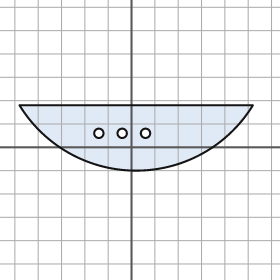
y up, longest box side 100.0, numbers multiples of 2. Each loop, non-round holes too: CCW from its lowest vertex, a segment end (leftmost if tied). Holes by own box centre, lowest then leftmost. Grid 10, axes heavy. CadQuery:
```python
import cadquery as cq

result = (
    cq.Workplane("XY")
    .moveTo(-48.0, 18.0)
    .threePointArc((2.0, -10.0), (52.0, 18.0))
    .close()
    .moveTo(-14.0, 6.0)
    .circle(2.0)
    .moveTo(-4.0, 6.0)
    .circle(2.0)
    .moveTo(6.0, 6.0)
    .circle(2.0)
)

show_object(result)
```